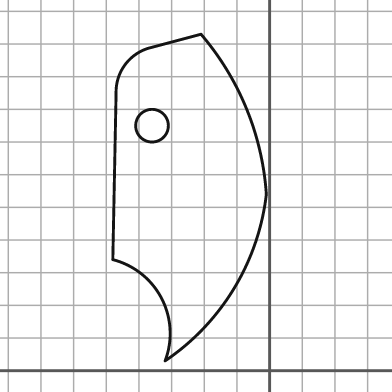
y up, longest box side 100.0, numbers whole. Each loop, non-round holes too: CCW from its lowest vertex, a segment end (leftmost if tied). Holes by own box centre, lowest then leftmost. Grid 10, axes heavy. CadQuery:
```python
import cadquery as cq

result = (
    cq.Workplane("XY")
    .moveTo(-32.0, 3.0)
    .threePointArc((-11.0, 25.0), (-1.0, 54.0))
    .threePointArc((-7.0, 80.0), (-21.0, 103.0))
    .lineTo(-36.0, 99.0)
    .threePointArc((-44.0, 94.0), (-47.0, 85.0))
    .lineTo(-48.0, 34.0)
    .threePointArc((-33.0, 22.0), (-32.0, 3.0))
    .close()
    .moveTo(-36.0, 75.0)
    .circle(5.0)
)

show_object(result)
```